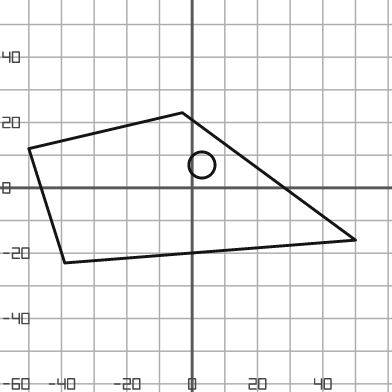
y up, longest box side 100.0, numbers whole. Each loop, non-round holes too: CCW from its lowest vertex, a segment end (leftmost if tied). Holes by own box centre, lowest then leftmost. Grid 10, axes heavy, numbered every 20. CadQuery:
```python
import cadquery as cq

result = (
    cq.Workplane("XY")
    .moveTo(-39.0, -23.0)
    .lineTo(50.0, -16.0)
    .lineTo(-3.0, 23.0)
    .lineTo(-50.0, 12.0)
    .close()
    .moveTo(3.0, 7.0)
    .circle(4.0)
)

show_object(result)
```